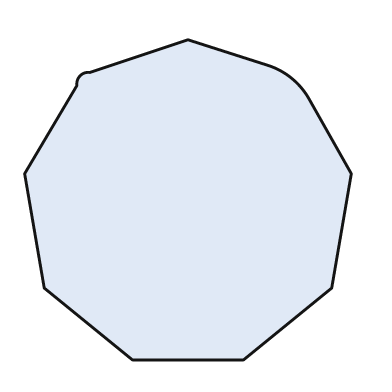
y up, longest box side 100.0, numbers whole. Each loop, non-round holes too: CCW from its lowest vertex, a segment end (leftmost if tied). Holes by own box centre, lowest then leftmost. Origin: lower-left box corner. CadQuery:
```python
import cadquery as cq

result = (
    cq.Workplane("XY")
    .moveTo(33.0, 0.0)
    .lineTo(67.0, 0.0)
    .lineTo(94.0, 22.0)
    .lineTo(100.0, 57.0)
    .lineTo(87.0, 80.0)
    .threePointArc((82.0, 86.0), (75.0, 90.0))
    .lineTo(50.0, 98.0)
    .lineTo(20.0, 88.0)
    .threePointArc((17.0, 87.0), (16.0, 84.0))
    .lineTo(0.0, 57.0)
    .lineTo(6.0, 22.0)
    .close()
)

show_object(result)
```